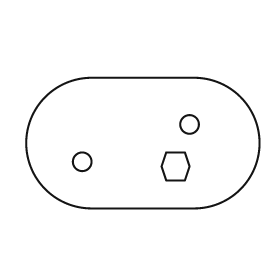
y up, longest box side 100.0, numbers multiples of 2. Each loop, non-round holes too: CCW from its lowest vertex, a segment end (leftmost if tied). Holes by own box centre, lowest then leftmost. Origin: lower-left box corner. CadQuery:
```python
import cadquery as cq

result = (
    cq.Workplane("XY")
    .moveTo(28.0, 0.0)
    .lineTo(72.0, 0.0)
    .threePointArc((100.0, 28.0), (72.0, 56.0))
    .lineTo(28.0, 56.0)
    .threePointArc((0.0, 28.0), (28.0, 0.0))
    .close()
    .moveTo(60.0, 12.0)
    .lineTo(68.0, 12.0)
    .lineTo(70.0, 18.0)
    .lineTo(68.0, 24.0)
    .lineTo(60.0, 24.0)
    .lineTo(58.0, 18.0)
    .close()
    .moveTo(24.0, 20.0)
    .circle(4.0)
    .moveTo(70.0, 36.0)
    .circle(4.0)
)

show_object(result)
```